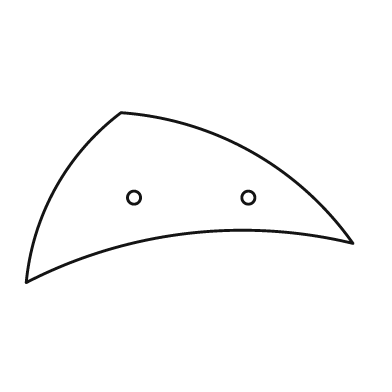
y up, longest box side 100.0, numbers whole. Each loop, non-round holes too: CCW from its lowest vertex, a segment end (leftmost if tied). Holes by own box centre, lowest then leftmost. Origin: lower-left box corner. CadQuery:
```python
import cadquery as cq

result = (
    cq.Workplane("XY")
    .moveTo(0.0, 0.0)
    .threePointArc((49.0, 15.0), (100.0, 12.0))
    .threePointArc((69.0, 40.0), (29.0, 52.0))
    .threePointArc((9.0, 29.0), (0.0, 0.0))
    .close()
    .moveTo(33.0, 26.0)
    .circle(2.0)
    .moveTo(68.0, 26.0)
    .circle(2.0)
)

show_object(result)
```